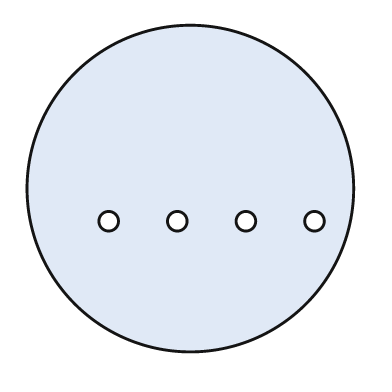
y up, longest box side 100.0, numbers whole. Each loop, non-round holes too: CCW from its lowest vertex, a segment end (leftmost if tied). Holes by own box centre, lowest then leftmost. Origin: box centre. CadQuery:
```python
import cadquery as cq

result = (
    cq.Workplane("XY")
    .moveTo(0.0, 0.0)
    .circle(50.0)
    .moveTo(-25.0, -10.0)
    .circle(3.0)
    .moveTo(-4.0, -10.0)
    .circle(3.0)
    .moveTo(17.0, -10.0)
    .circle(3.0)
    .moveTo(38.0, -10.0)
    .circle(3.0)
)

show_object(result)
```